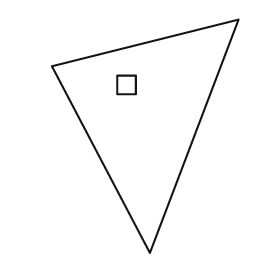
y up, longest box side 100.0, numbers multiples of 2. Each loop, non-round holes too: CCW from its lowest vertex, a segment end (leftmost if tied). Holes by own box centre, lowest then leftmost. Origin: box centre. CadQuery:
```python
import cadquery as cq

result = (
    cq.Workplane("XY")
    .moveTo(2.0, -50.0)
    .lineTo(40.0, 50.0)
    .lineTo(-40.0, 30.0)
    .close()
    .moveTo(-12.0, 18.0)
    .lineTo(-4.0, 18.0)
    .lineTo(-4.0, 26.0)
    .lineTo(-12.0, 26.0)
    .close()
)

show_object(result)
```